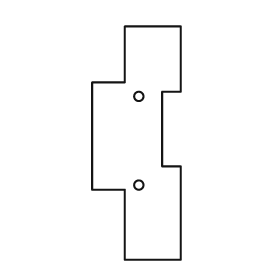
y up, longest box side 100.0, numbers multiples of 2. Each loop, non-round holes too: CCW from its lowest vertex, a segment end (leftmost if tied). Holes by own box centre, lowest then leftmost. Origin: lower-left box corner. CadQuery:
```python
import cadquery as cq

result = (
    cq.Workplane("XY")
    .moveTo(14.0, 0.0)
    .lineTo(38.0, 0.0)
    .lineTo(38.0, 40.0)
    .lineTo(30.0, 40.0)
    .lineTo(30.0, 72.0)
    .lineTo(38.0, 72.0)
    .lineTo(38.0, 100.0)
    .lineTo(14.0, 100.0)
    .lineTo(14.0, 76.0)
    .lineTo(0.0, 76.0)
    .lineTo(0.0, 30.0)
    .lineTo(14.0, 30.0)
    .close()
    .moveTo(20.0, 32.0)
    .circle(2.0)
    .moveTo(20.0, 70.0)
    .circle(2.0)
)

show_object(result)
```